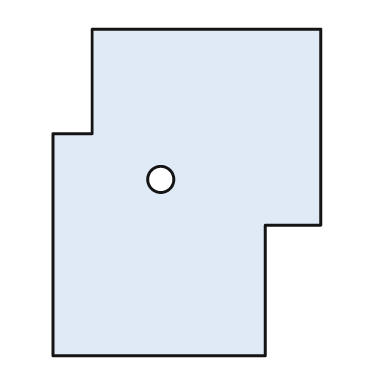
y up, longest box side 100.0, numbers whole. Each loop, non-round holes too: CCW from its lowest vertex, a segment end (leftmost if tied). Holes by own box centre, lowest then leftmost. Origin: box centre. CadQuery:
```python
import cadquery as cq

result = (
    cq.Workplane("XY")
    .moveTo(-41.0, -50.0)
    .lineTo(24.0, -50.0)
    .lineTo(24.0, -10.0)
    .lineTo(41.0, -10.0)
    .lineTo(41.0, 50.0)
    .lineTo(-29.0, 50.0)
    .lineTo(-29.0, 18.0)
    .lineTo(-41.0, 18.0)
    .close()
    .moveTo(-8.0, 4.0)
    .circle(4.0)
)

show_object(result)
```